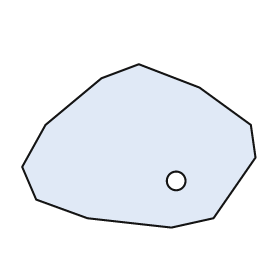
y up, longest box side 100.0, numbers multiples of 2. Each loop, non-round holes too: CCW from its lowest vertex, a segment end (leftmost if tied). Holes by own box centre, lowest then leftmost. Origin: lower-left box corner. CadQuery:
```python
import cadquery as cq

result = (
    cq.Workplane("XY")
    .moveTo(64.0, 0.0)
    .lineTo(82.0, 4.0)
    .lineTo(100.0, 30.0)
    .lineTo(98.0, 44.0)
    .lineTo(76.0, 60.0)
    .lineTo(50.0, 70.0)
    .lineTo(34.0, 64.0)
    .lineTo(10.0, 44.0)
    .lineTo(0.0, 26.0)
    .lineTo(6.0, 12.0)
    .lineTo(28.0, 4.0)
    .close()
    .moveTo(66.0, 20.0)
    .circle(4.0)
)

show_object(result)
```